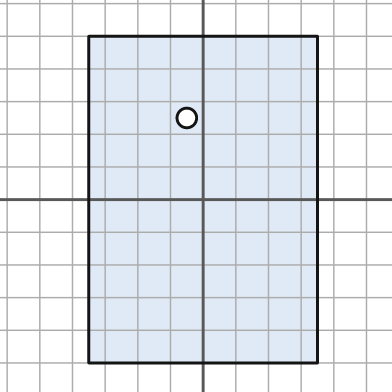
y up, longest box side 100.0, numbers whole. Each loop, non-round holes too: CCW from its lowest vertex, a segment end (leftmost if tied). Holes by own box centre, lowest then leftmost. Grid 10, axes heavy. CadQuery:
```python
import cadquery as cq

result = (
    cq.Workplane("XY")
    .moveTo(-35.0, -50.0)
    .lineTo(35.0, -50.0)
    .lineTo(35.0, 50.0)
    .lineTo(-35.0, 50.0)
    .close()
    .moveTo(-5.0, 25.0)
    .circle(3.0)
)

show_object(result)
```